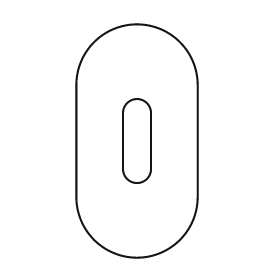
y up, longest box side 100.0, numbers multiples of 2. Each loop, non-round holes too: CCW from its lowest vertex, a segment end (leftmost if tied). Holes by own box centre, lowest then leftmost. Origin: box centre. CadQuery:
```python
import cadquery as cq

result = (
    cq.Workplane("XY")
    .moveTo(-26.0, -24.0)
    .threePointArc((0.0, -50.0), (26.0, -24.0))
    .lineTo(26.0, 24.0)
    .threePointArc((0.0, 50.0), (-26.0, 24.0))
    .close()
    .moveTo(-6.0, -12.0)
    .threePointArc((0.0, -18.0), (6.0, -12.0))
    .lineTo(6.0, 12.0)
    .threePointArc((0.0, 18.0), (-6.0, 12.0))
    .close()
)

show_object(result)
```